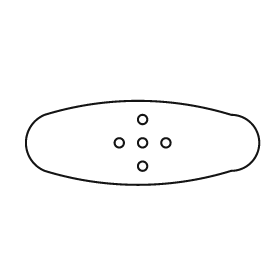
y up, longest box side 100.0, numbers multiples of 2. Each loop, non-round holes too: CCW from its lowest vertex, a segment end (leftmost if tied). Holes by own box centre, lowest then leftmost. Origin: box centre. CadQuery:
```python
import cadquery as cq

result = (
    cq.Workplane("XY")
    .moveTo(-42.0, -12.0)
    .threePointArc((-2.0, -18.0), (38.0, -12.0))
    .threePointArc((50.0, 0.0), (38.0, 12.0))
    .threePointArc((-2.0, 18.0), (-42.0, 12.0))
    .threePointArc((-50.0, 0.0), (-42.0, -12.0))
    .close()
    .moveTo(0.0, -10.0)
    .circle(2.0)
    .moveTo(-10.0, 0.0)
    .circle(2.0)
    .moveTo(0.0, 0.0)
    .circle(2.0)
    .moveTo(10.0, 0.0)
    .circle(2.0)
    .moveTo(0.0, 10.0)
    .circle(2.0)
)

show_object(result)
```